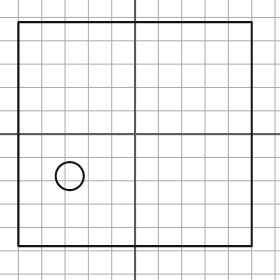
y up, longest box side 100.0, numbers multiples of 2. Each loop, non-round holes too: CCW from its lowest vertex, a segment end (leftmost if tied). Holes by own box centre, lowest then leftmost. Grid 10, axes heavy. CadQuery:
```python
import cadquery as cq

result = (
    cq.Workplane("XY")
    .moveTo(-50.0, -48.0)
    .lineTo(50.0, -48.0)
    .lineTo(50.0, 48.0)
    .lineTo(-50.0, 48.0)
    .close()
    .moveTo(-28.0, -18.0)
    .circle(6.0)
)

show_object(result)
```